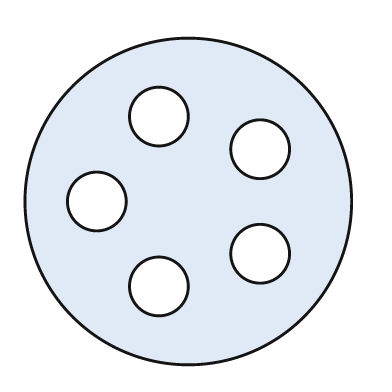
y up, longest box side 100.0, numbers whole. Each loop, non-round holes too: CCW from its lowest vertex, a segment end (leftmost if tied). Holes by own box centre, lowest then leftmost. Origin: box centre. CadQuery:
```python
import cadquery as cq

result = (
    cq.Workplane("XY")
    .moveTo(0.0, 0.0)
    .circle(50.0)
    .moveTo(-9.0, -26.0)
    .circle(9.0)
    .moveTo(22.0, -16.0)
    .circle(9.0)
    .moveTo(-28.0, 0.0)
    .circle(9.0)
    .moveTo(22.0, 16.0)
    .circle(9.0)
    .moveTo(-9.0, 26.0)
    .circle(9.0)
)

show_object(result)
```